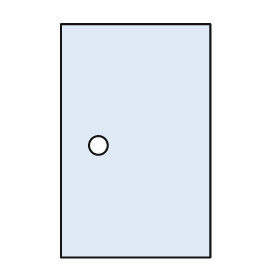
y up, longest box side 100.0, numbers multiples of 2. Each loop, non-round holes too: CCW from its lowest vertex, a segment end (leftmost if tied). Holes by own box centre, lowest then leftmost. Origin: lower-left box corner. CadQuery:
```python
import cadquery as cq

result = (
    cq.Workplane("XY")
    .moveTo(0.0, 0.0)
    .lineTo(64.0, 0.0)
    .lineTo(64.0, 100.0)
    .lineTo(0.0, 100.0)
    .close()
    .moveTo(16.0, 48.0)
    .circle(4.0)
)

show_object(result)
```